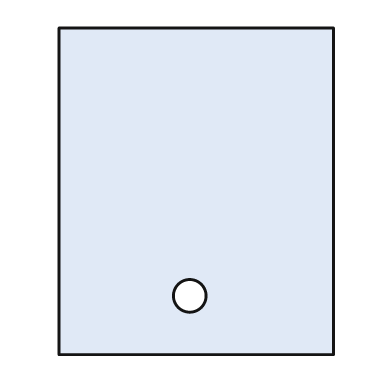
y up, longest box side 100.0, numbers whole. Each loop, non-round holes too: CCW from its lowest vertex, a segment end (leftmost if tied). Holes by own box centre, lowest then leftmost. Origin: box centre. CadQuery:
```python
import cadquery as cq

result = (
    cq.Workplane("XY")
    .moveTo(-42.0, -50.0)
    .lineTo(42.0, -50.0)
    .lineTo(42.0, 50.0)
    .lineTo(-42.0, 50.0)
    .close()
    .moveTo(-2.0, -32.0)
    .circle(5.0)
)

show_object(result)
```